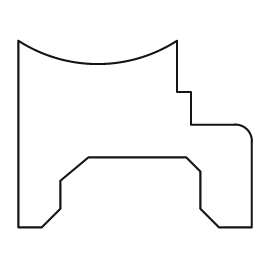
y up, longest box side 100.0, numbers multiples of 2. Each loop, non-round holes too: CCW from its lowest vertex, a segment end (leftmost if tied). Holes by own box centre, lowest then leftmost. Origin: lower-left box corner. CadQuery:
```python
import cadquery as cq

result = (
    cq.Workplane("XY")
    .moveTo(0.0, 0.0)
    .lineTo(10.0, 0.0)
    .lineTo(18.0, 8.0)
    .lineTo(18.0, 20.0)
    .lineTo(30.0, 30.0)
    .lineTo(72.0, 30.0)
    .lineTo(78.0, 24.0)
    .lineTo(78.0, 8.0)
    .lineTo(86.0, 0.0)
    .lineTo(100.0, 0.0)
    .lineTo(100.0, 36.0)
    .threePointArc((98.0, 42.0), (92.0, 44.0))
    .lineTo(74.0, 44.0)
    .lineTo(74.0, 58.0)
    .lineTo(68.0, 58.0)
    .lineTo(68.0, 80.0)
    .threePointArc((34.0, 70.0), (0.0, 80.0))
    .close()
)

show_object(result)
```